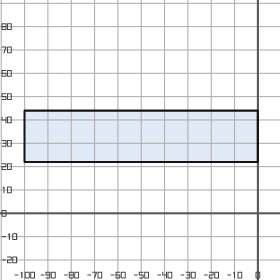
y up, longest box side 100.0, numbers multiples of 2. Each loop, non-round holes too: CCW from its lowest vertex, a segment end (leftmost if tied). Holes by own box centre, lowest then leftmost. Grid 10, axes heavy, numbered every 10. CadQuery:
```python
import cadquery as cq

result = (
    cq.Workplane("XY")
    .moveTo(-100.0, 22.0)
    .lineTo(0.0, 22.0)
    .lineTo(0.0, 44.0)
    .lineTo(-100.0, 44.0)
    .close()
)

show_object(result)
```